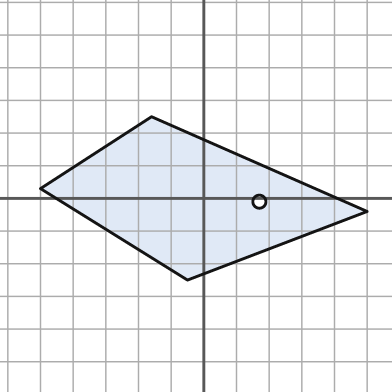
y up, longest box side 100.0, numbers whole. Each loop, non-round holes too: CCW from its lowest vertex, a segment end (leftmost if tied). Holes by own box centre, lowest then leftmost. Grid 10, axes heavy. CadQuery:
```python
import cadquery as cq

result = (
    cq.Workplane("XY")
    .moveTo(-5.0, -25.0)
    .lineTo(50.0, -4.0)
    .lineTo(-16.0, 25.0)
    .lineTo(-50.0, 3.0)
    .close()
    .moveTo(17.0, -1.0)
    .circle(2.0)
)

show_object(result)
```